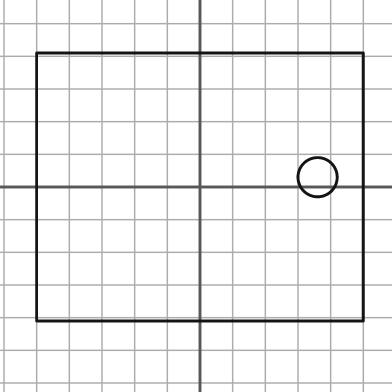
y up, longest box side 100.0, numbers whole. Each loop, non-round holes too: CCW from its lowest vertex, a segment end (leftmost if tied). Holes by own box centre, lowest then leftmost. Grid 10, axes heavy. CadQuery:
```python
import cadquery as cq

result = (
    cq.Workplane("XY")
    .moveTo(-50.0, -41.0)
    .lineTo(50.0, -41.0)
    .lineTo(50.0, 41.0)
    .lineTo(-50.0, 41.0)
    .close()
    .moveTo(36.0, 3.0)
    .circle(6.0)
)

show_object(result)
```